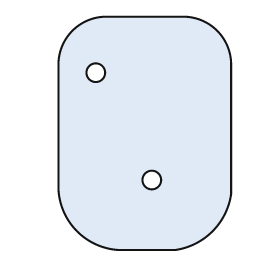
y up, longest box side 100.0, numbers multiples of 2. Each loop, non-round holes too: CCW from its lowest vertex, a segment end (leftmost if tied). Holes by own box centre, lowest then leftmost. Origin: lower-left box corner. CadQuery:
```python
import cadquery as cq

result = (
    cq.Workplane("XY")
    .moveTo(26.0, 0.0)
    .lineTo(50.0, 0.0)
    .threePointArc((66.0, 8.0), (74.0, 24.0))
    .lineTo(74.0, 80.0)
    .threePointArc((68.0, 94.0), (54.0, 100.0))
    .lineTo(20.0, 100.0)
    .threePointArc((6.0, 94.0), (0.0, 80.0))
    .lineTo(0.0, 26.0)
    .threePointArc((8.0, 8.0), (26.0, 0.0))
    .close()
    .moveTo(40.0, 30.0)
    .circle(4.0)
    .moveTo(16.0, 76.0)
    .circle(4.0)
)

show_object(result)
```